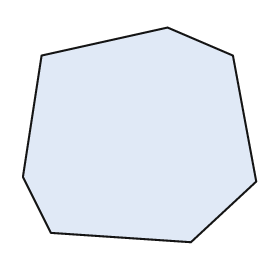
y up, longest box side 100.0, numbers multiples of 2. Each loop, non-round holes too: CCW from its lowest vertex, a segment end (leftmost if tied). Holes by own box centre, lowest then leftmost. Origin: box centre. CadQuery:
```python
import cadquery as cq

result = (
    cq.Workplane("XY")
    .moveTo(22.0, -46.0)
    .lineTo(50.0, -20.0)
    .lineTo(40.0, 34.0)
    .lineTo(12.0, 46.0)
    .lineTo(-42.0, 34.0)
    .lineTo(-50.0, -18.0)
    .lineTo(-38.0, -42.0)
    .close()
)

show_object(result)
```